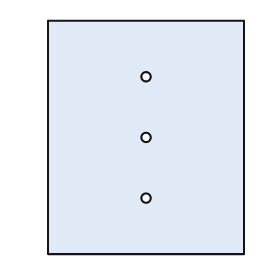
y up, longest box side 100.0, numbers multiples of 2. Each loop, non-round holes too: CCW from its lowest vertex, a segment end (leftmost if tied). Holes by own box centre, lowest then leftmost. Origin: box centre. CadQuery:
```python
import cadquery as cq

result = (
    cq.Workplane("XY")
    .moveTo(-42.0, -50.0)
    .lineTo(42.0, -50.0)
    .lineTo(42.0, 50.0)
    .lineTo(-42.0, 50.0)
    .close()
    .moveTo(0.0, -26.0)
    .circle(2.0)
    .moveTo(0.0, 0.0)
    .circle(2.0)
    .moveTo(0.0, 26.0)
    .circle(2.0)
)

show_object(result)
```